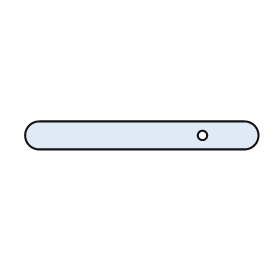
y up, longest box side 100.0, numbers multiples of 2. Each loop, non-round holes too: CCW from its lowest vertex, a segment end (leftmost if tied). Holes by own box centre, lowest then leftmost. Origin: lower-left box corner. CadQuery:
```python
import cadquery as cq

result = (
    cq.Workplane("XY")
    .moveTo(6.0, 0.0)
    .lineTo(94.0, 0.0)
    .threePointArc((100.0, 6.0), (94.0, 12.0))
    .lineTo(6.0, 12.0)
    .threePointArc((0.0, 6.0), (6.0, 0.0))
    .close()
    .moveTo(76.0, 6.0)
    .circle(2.0)
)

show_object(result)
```